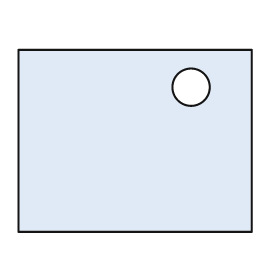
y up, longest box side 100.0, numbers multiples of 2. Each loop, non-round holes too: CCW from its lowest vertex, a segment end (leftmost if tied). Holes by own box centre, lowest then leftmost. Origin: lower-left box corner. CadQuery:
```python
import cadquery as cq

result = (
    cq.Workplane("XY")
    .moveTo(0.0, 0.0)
    .lineTo(100.0, 0.0)
    .lineTo(100.0, 78.0)
    .lineTo(0.0, 78.0)
    .close()
    .moveTo(74.0, 62.0)
    .circle(8.0)
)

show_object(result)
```